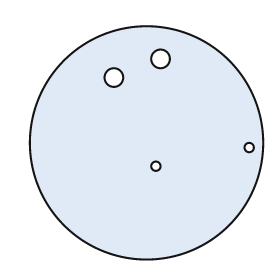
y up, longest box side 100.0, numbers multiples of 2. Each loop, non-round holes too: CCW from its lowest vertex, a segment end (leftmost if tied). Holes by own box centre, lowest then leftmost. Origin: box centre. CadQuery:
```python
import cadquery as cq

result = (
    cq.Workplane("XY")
    .moveTo(0.0, 0.0)
    .circle(50.0)
    .moveTo(4.0, -10.0)
    .circle(2.0)
    .moveTo(44.0, -2.0)
    .circle(2.0)
    .moveTo(-14.0, 28.0)
    .circle(4.0)
    .moveTo(6.0, 36.0)
    .circle(4.0)
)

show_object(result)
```